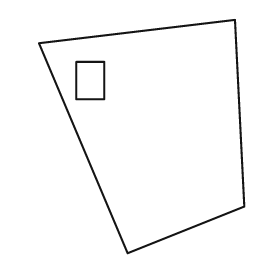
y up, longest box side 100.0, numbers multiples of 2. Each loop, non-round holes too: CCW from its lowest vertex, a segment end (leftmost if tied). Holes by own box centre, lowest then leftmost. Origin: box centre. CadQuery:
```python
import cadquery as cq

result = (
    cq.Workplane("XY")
    .moveTo(-6.0, -50.0)
    .lineTo(44.0, -30.0)
    .lineTo(40.0, 50.0)
    .lineTo(-44.0, 40.0)
    .close()
    .moveTo(-28.0, 16.0)
    .lineTo(-16.0, 16.0)
    .lineTo(-16.0, 32.0)
    .lineTo(-28.0, 32.0)
    .close()
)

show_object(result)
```